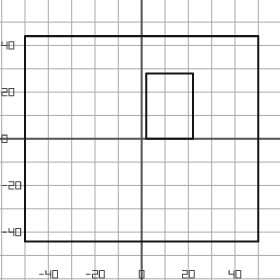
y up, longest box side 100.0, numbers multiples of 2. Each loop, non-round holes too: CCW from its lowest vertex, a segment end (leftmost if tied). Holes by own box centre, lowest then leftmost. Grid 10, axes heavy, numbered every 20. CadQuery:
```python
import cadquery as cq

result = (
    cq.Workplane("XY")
    .moveTo(-50.0, -44.0)
    .lineTo(50.0, -44.0)
    .lineTo(50.0, 44.0)
    .lineTo(-50.0, 44.0)
    .close()
    .moveTo(2.0, 0.0)
    .lineTo(22.0, 0.0)
    .lineTo(22.0, 28.0)
    .lineTo(2.0, 28.0)
    .close()
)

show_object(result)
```